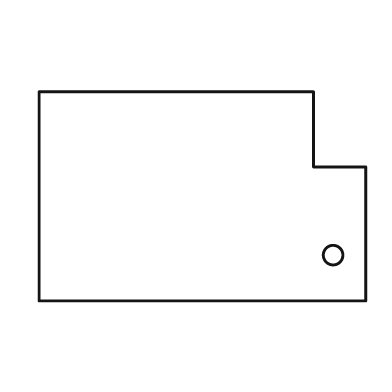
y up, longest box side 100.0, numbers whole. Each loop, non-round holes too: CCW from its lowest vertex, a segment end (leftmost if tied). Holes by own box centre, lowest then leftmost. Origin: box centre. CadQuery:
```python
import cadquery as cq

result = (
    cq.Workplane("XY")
    .moveTo(-50.0, -32.0)
    .lineTo(50.0, -32.0)
    .lineTo(50.0, 9.0)
    .lineTo(34.0, 9.0)
    .lineTo(34.0, 32.0)
    .lineTo(-50.0, 32.0)
    .close()
    .moveTo(40.0, -18.0)
    .circle(3.0)
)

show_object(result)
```